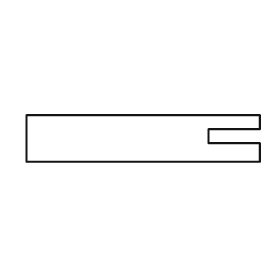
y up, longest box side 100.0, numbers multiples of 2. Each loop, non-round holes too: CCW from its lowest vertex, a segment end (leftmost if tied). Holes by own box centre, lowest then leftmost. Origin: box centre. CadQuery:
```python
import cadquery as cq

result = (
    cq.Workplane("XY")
    .moveTo(-50.0, -10.0)
    .lineTo(50.0, -10.0)
    .lineTo(50.0, -2.0)
    .lineTo(28.0, -2.0)
    .lineTo(28.0, 4.0)
    .lineTo(50.0, 4.0)
    .lineTo(50.0, 10.0)
    .lineTo(-50.0, 10.0)
    .close()
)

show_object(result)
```